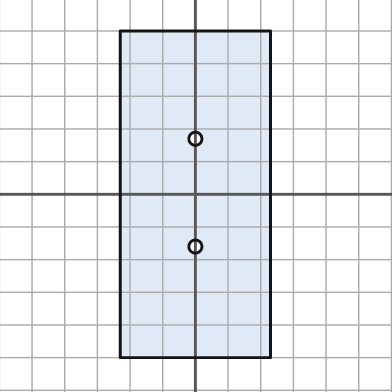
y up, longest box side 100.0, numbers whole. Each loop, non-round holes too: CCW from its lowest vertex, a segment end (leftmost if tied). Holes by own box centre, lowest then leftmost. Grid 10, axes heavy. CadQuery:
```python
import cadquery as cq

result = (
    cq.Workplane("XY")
    .moveTo(-23.0, -50.0)
    .lineTo(23.0, -50.0)
    .lineTo(23.0, 50.0)
    .lineTo(-23.0, 50.0)
    .close()
    .moveTo(0.0, -16.0)
    .circle(2.0)
    .moveTo(0.0, 17.0)
    .circle(2.0)
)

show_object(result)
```